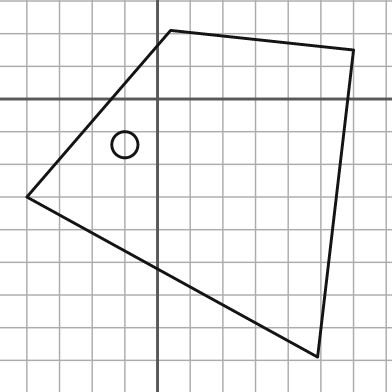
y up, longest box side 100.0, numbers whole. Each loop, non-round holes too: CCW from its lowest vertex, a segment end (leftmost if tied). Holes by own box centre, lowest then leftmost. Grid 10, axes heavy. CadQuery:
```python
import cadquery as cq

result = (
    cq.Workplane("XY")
    .moveTo(49.0, -79.0)
    .lineTo(60.0, 15.0)
    .lineTo(4.0, 21.0)
    .lineTo(-40.0, -30.0)
    .close()
    .moveTo(-10.0, -14.0)
    .circle(4.0)
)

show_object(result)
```